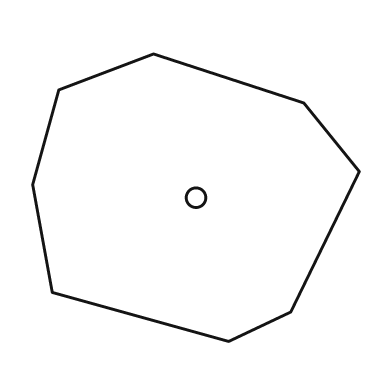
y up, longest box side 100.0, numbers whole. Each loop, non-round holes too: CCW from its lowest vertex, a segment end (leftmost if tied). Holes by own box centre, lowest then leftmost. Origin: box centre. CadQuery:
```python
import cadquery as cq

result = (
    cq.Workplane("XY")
    .moveTo(10.0, -44.0)
    .lineTo(29.0, -35.0)
    .lineTo(50.0, 8.0)
    .lineTo(33.0, 29.0)
    .lineTo(-13.0, 44.0)
    .lineTo(-42.0, 33.0)
    .lineTo(-50.0, 4.0)
    .lineTo(-44.0, -29.0)
    .close()
    .moveTo(0.0, 0.0)
    .circle(3.0)
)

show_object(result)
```